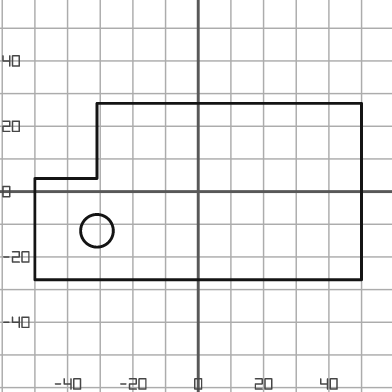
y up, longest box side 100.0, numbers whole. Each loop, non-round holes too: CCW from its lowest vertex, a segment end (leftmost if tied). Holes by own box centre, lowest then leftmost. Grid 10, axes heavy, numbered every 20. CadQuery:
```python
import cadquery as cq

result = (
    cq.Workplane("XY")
    .moveTo(-50.0, -27.0)
    .lineTo(50.0, -27.0)
    .lineTo(50.0, 27.0)
    .lineTo(-31.0, 27.0)
    .lineTo(-31.0, 4.0)
    .lineTo(-50.0, 4.0)
    .close()
    .moveTo(-31.0, -12.0)
    .circle(5.0)
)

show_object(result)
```